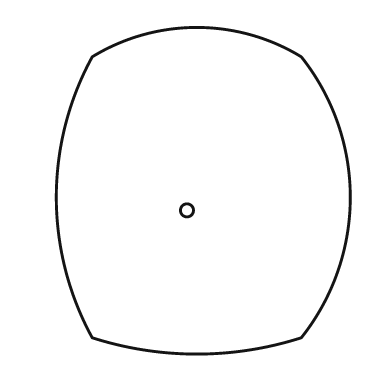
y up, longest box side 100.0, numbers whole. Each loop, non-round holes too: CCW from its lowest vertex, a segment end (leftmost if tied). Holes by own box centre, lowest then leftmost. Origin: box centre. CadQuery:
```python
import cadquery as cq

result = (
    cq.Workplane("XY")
    .moveTo(-34.0, -45.0)
    .threePointArc((-2.0, -50.0), (30.0, -45.0))
    .threePointArc((45.0, -2.0), (30.0, 41.0))
    .threePointArc((-2.0, 50.0), (-34.0, 41.0))
    .threePointArc((-45.0, -2.0), (-34.0, -45.0))
    .close()
    .moveTo(-5.0, -6.0)
    .circle(2.0)
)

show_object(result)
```